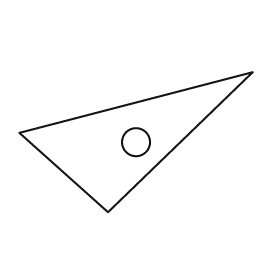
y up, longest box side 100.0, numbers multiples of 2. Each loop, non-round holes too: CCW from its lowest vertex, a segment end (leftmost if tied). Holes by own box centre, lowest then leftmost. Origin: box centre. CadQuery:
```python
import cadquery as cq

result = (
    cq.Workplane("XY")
    .moveTo(-12.0, -30.0)
    .lineTo(50.0, 30.0)
    .lineTo(-50.0, 4.0)
    .close()
    .moveTo(0.0, 0.0)
    .circle(6.0)
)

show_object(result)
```